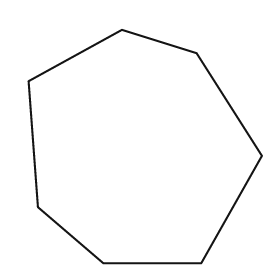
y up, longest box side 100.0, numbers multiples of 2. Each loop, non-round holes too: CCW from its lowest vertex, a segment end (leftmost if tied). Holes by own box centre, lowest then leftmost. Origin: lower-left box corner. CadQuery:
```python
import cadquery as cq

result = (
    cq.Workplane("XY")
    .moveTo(32.0, 0.0)
    .lineTo(74.0, 0.0)
    .lineTo(100.0, 46.0)
    .lineTo(72.0, 90.0)
    .lineTo(40.0, 100.0)
    .lineTo(0.0, 78.0)
    .lineTo(4.0, 24.0)
    .close()
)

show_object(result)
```